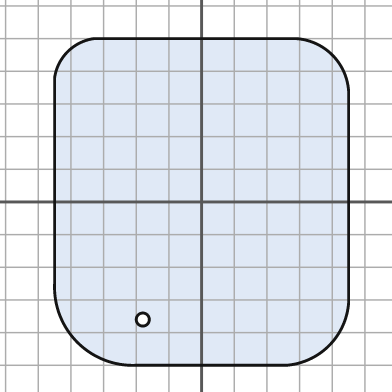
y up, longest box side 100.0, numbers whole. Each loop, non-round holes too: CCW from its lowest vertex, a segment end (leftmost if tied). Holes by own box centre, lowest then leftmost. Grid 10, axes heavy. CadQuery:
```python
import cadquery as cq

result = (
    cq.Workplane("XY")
    .moveTo(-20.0, -50.0)
    .lineTo(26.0, -50.0)
    .threePointArc((39.0, -44.0), (45.0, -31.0))
    .lineTo(45.0, 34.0)
    .threePointArc((40.0, 45.0), (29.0, 50.0))
    .lineTo(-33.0, 50.0)
    .threePointArc((-41.0, 46.0), (-45.0, 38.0))
    .lineTo(-45.0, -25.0)
    .threePointArc((-38.0, -43.0), (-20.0, -50.0))
    .close()
    .moveTo(-18.0, -36.0)
    .circle(2.0)
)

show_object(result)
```